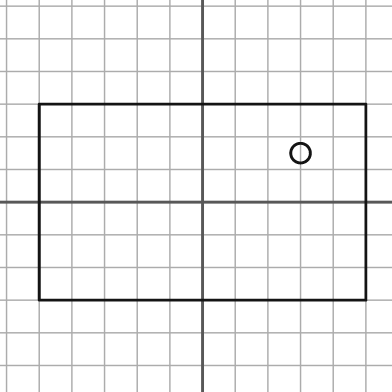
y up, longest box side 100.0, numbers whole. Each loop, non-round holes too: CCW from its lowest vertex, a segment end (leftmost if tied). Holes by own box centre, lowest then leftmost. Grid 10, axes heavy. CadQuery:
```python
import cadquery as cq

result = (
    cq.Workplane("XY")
    .moveTo(-50.0, -30.0)
    .lineTo(50.0, -30.0)
    .lineTo(50.0, 30.0)
    .lineTo(-50.0, 30.0)
    .close()
    .moveTo(30.0, 15.0)
    .circle(3.0)
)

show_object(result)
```